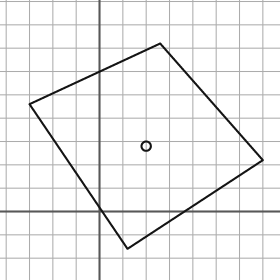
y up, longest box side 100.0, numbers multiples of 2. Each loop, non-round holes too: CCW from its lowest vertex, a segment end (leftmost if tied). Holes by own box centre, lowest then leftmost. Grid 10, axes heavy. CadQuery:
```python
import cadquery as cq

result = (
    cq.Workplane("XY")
    .moveTo(12.0, -16.0)
    .lineTo(70.0, 22.0)
    .lineTo(26.0, 72.0)
    .lineTo(-30.0, 46.0)
    .close()
    .moveTo(20.0, 28.0)
    .circle(2.0)
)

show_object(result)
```